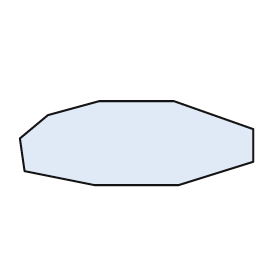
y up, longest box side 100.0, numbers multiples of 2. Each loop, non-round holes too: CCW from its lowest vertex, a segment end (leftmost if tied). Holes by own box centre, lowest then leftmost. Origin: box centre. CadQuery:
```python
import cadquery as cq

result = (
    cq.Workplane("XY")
    .moveTo(-18.0, -18.0)
    .lineTo(18.0, -18.0)
    .lineTo(50.0, -8.0)
    .lineTo(50.0, 6.0)
    .lineTo(16.0, 18.0)
    .lineTo(-16.0, 18.0)
    .lineTo(-38.0, 12.0)
    .lineTo(-50.0, 2.0)
    .lineTo(-48.0, -12.0)
    .close()
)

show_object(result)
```